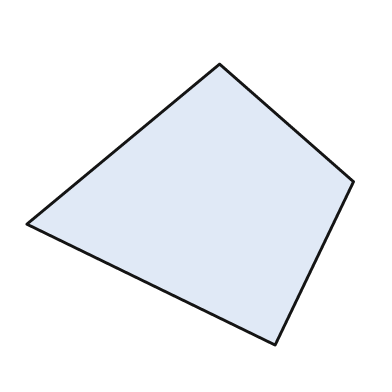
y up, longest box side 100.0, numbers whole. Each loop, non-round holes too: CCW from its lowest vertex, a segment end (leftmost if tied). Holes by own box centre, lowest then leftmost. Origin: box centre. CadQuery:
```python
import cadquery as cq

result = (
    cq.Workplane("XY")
    .moveTo(26.0, -43.0)
    .lineTo(50.0, 7.0)
    .lineTo(9.0, 43.0)
    .lineTo(-50.0, -6.0)
    .close()
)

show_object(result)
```